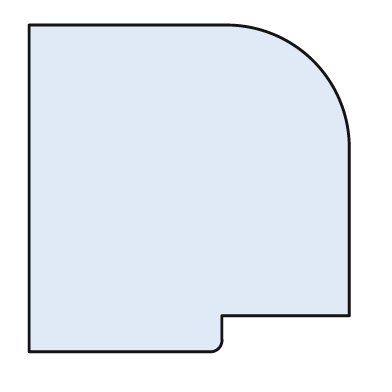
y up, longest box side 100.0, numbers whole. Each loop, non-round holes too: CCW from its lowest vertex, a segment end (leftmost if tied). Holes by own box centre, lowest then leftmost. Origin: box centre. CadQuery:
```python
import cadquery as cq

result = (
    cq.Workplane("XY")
    .moveTo(-49.0, -50.0)
    .lineTo(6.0, -50.0)
    .threePointArc((9.0, -49.0), (10.0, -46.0))
    .lineTo(10.0, -39.0)
    .lineTo(49.0, -39.0)
    .lineTo(49.0, 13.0)
    .threePointArc((38.0, 39.0), (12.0, 50.0))
    .lineTo(-49.0, 50.0)
    .close()
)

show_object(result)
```